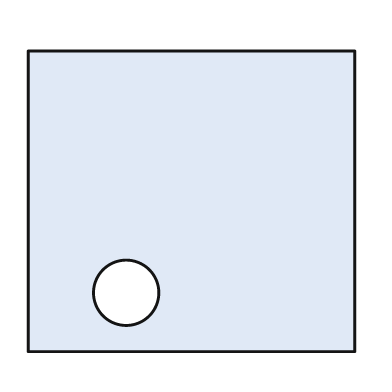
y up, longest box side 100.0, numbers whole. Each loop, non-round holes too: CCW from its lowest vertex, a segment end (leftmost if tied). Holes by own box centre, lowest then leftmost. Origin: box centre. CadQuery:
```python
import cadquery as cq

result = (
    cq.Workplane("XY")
    .moveTo(-50.0, -46.0)
    .lineTo(50.0, -46.0)
    .lineTo(50.0, 46.0)
    .lineTo(-50.0, 46.0)
    .close()
    .moveTo(-20.0, -28.0)
    .circle(10.0)
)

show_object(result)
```